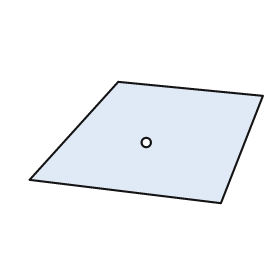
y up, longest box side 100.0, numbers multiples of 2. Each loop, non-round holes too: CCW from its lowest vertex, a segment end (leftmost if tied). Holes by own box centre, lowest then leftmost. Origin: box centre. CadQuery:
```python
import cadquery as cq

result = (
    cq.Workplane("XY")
    .moveTo(32.0, -26.0)
    .lineTo(50.0, 20.0)
    .lineTo(-12.0, 26.0)
    .lineTo(-50.0, -16.0)
    .close()
    .moveTo(0.0, 0.0)
    .circle(2.0)
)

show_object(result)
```